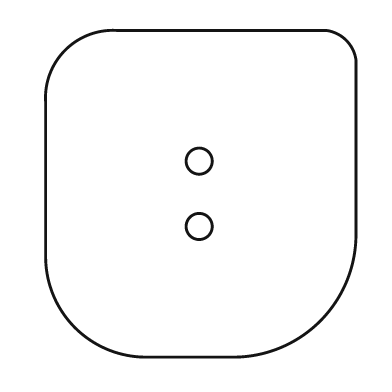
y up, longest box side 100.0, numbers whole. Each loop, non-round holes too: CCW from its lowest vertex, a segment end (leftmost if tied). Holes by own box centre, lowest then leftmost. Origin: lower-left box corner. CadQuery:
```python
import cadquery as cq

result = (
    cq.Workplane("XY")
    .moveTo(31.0, 0.0)
    .lineTo(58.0, 0.0)
    .threePointArc((84.0, 11.0), (95.0, 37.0))
    .lineTo(95.0, 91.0)
    .threePointArc((92.0, 97.0), (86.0, 100.0))
    .lineTo(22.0, 100.0)
    .threePointArc((6.0, 94.0), (0.0, 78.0))
    .lineTo(0.0, 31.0)
    .threePointArc((9.0, 9.0), (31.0, 0.0))
    .close()
    .moveTo(47.0, 40.0)
    .circle(4.0)
    .moveTo(47.0, 60.0)
    .circle(4.0)
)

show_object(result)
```